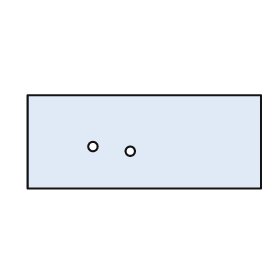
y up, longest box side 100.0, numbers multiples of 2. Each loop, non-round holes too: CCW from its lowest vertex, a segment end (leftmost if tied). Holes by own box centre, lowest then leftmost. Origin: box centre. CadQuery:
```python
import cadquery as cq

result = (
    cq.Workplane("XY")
    .moveTo(-50.0, -20.0)
    .lineTo(50.0, -20.0)
    .lineTo(50.0, 20.0)
    .lineTo(-50.0, 20.0)
    .close()
    .moveTo(-6.0, -4.0)
    .circle(2.0)
    .moveTo(-22.0, -2.0)
    .circle(2.0)
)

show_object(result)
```